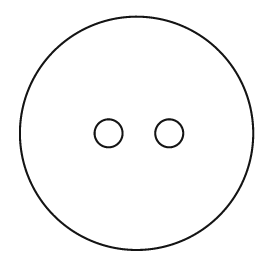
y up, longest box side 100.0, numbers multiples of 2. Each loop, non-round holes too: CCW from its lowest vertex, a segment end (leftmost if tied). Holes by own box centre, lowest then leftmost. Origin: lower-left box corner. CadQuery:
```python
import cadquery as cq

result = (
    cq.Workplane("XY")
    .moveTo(50.0, 50.0)
    .circle(50.0)
    .moveTo(38.0, 50.0)
    .circle(6.0)
    .moveTo(64.0, 50.0)
    .circle(6.0)
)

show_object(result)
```